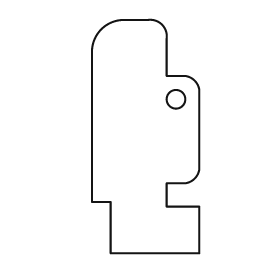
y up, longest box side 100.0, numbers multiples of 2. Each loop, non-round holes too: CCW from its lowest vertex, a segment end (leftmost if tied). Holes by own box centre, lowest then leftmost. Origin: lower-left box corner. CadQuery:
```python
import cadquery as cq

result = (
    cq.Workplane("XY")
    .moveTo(8.0, 0.0)
    .lineTo(46.0, 0.0)
    .lineTo(46.0, 20.0)
    .lineTo(32.0, 20.0)
    .lineTo(32.0, 30.0)
    .lineTo(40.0, 30.0)
    .threePointArc((44.0, 32.0), (46.0, 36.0))
    .lineTo(46.0, 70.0)
    .threePointArc((44.0, 74.0), (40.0, 76.0))
    .lineTo(32.0, 76.0)
    .lineTo(32.0, 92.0)
    .threePointArc((30.0, 98.0), (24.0, 100.0))
    .lineTo(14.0, 100.0)
    .threePointArc((4.0, 96.0), (0.0, 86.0))
    .lineTo(0.0, 22.0)
    .lineTo(8.0, 22.0)
    .close()
    .moveTo(36.0, 66.0)
    .circle(4.0)
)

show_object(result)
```